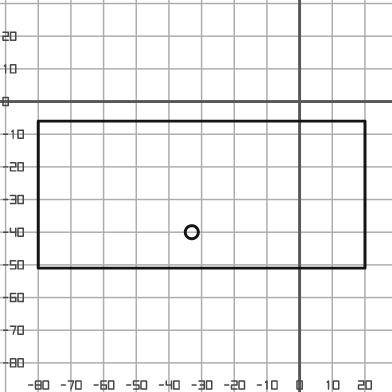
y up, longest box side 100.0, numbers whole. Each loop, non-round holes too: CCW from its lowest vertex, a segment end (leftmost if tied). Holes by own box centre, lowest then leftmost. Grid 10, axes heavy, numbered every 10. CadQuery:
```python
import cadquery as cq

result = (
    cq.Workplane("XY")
    .moveTo(-80.0, -51.0)
    .lineTo(20.0, -51.0)
    .lineTo(20.0, -6.0)
    .lineTo(-80.0, -6.0)
    .close()
    .moveTo(-33.0, -40.0)
    .circle(2.0)
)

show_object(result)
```